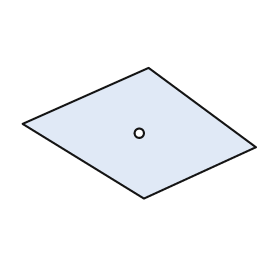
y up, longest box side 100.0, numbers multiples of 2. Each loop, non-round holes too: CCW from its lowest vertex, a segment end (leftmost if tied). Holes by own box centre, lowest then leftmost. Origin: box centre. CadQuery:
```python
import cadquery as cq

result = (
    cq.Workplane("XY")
    .moveTo(2.0, -28.0)
    .lineTo(50.0, -6.0)
    .lineTo(4.0, 28.0)
    .lineTo(-50.0, 4.0)
    .close()
    .moveTo(0.0, 0.0)
    .circle(2.0)
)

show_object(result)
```